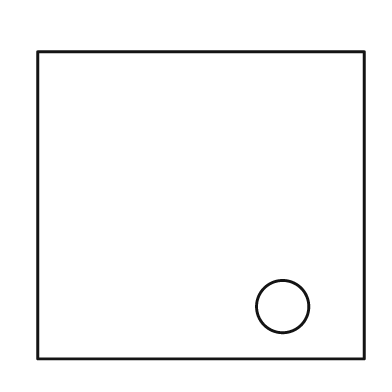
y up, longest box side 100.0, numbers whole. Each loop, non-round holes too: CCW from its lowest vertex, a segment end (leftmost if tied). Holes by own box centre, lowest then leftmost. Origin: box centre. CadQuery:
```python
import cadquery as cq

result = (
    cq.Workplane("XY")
    .moveTo(-50.0, -47.0)
    .lineTo(50.0, -47.0)
    .lineTo(50.0, 47.0)
    .lineTo(-50.0, 47.0)
    .close()
    .moveTo(25.0, -31.0)
    .circle(8.0)
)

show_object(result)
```